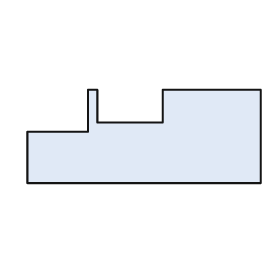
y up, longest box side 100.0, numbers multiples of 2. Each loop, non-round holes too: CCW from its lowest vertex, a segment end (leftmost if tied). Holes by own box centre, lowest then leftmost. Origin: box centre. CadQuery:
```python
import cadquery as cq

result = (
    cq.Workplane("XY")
    .moveTo(-50.0, -20.0)
    .lineTo(50.0, -20.0)
    .lineTo(50.0, 20.0)
    .lineTo(8.0, 20.0)
    .lineTo(8.0, 6.0)
    .lineTo(-20.0, 6.0)
    .lineTo(-20.0, 20.0)
    .lineTo(-24.0, 20.0)
    .lineTo(-24.0, 2.0)
    .lineTo(-50.0, 2.0)
    .close()
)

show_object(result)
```